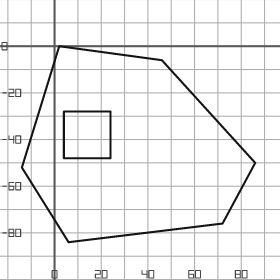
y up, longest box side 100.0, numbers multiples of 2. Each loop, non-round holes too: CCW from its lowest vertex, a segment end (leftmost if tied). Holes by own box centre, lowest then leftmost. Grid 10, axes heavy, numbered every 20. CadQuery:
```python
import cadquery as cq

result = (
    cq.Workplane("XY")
    .moveTo(6.0, -84.0)
    .lineTo(72.0, -76.0)
    .lineTo(86.0, -50.0)
    .lineTo(46.0, -6.0)
    .lineTo(2.0, 0.0)
    .lineTo(-14.0, -52.0)
    .close()
    .moveTo(4.0, -48.0)
    .lineTo(24.0, -48.0)
    .lineTo(24.0, -28.0)
    .lineTo(4.0, -28.0)
    .close()
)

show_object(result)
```